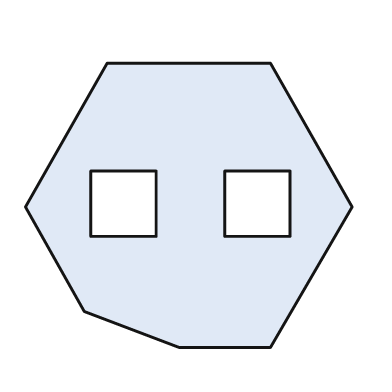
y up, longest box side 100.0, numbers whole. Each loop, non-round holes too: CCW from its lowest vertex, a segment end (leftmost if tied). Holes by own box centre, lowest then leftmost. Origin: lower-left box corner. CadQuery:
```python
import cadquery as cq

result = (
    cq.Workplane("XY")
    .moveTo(47.0, 0.0)
    .lineTo(75.0, 0.0)
    .lineTo(100.0, 43.0)
    .lineTo(75.0, 87.0)
    .lineTo(25.0, 87.0)
    .lineTo(0.0, 43.0)
    .lineTo(18.0, 11.0)
    .close()
    .moveTo(20.0, 34.0)
    .lineTo(40.0, 34.0)
    .lineTo(40.0, 54.0)
    .lineTo(20.0, 54.0)
    .close()
    .moveTo(61.0, 34.0)
    .lineTo(81.0, 34.0)
    .lineTo(81.0, 54.0)
    .lineTo(61.0, 54.0)
    .close()
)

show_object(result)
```